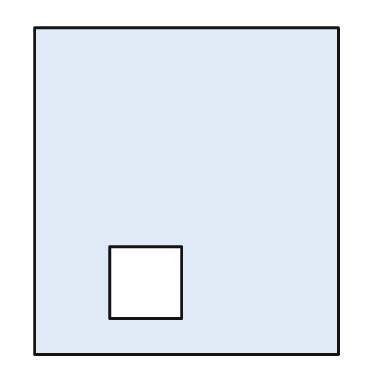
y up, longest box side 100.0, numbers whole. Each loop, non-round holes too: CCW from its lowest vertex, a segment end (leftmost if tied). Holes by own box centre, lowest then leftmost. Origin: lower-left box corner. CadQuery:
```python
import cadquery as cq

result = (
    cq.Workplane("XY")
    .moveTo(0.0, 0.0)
    .lineTo(93.0, 0.0)
    .lineTo(93.0, 100.0)
    .lineTo(0.0, 100.0)
    .close()
    .moveTo(23.0, 11.0)
    .lineTo(45.0, 11.0)
    .lineTo(45.0, 33.0)
    .lineTo(23.0, 33.0)
    .close()
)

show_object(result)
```